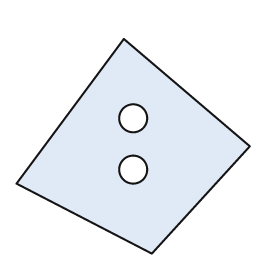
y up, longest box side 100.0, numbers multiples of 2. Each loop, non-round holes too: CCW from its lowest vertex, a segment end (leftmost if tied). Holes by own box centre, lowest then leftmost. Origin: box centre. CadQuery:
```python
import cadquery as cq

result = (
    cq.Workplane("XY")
    .moveTo(8.0, -46.0)
    .lineTo(50.0, 0.0)
    .lineTo(-4.0, 46.0)
    .lineTo(-50.0, -16.0)
    .close()
    .moveTo(0.0, -10.0)
    .circle(6.0)
    .moveTo(0.0, 12.0)
    .circle(6.0)
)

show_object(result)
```